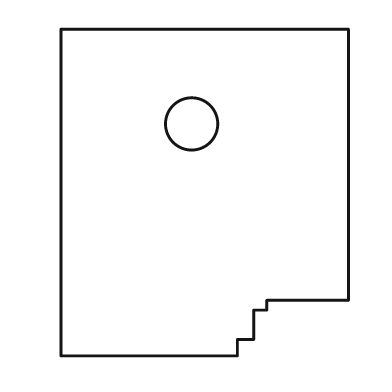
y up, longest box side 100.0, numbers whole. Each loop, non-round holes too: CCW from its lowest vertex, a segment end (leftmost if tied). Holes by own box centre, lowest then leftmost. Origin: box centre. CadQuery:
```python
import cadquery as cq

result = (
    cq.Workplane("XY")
    .moveTo(-44.0, -50.0)
    .lineTo(10.0, -50.0)
    .lineTo(10.0, -45.0)
    .lineTo(15.0, -45.0)
    .lineTo(15.0, -36.0)
    .lineTo(19.0, -36.0)
    .lineTo(19.0, -33.0)
    .lineTo(44.0, -33.0)
    .lineTo(44.0, 50.0)
    .lineTo(-44.0, 50.0)
    .close()
    .moveTo(-4.0, 21.0)
    .circle(8.0)
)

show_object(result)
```